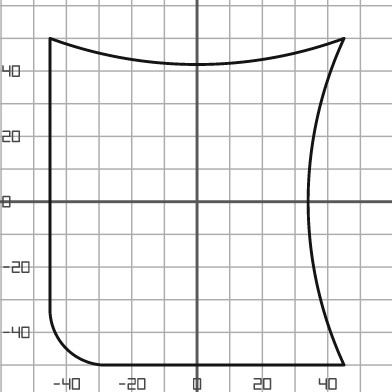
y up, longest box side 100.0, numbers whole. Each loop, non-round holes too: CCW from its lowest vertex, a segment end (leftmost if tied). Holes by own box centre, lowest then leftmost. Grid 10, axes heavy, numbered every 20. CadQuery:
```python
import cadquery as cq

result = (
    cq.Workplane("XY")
    .moveTo(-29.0, -50.0)
    .lineTo(45.0, -50.0)
    .threePointArc((34.0, 0.0), (45.0, 50.0))
    .threePointArc((0.0, 42.0), (-45.0, 50.0))
    .lineTo(-45.0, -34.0)
    .threePointArc((-40.0, -45.0), (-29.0, -50.0))
    .close()
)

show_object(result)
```